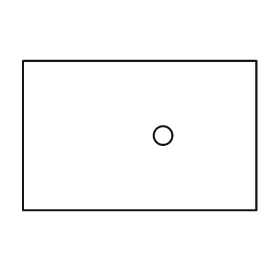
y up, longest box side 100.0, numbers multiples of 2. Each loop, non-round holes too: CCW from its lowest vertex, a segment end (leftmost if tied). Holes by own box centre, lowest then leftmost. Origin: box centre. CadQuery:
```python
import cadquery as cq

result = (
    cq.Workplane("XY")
    .moveTo(-50.0, -32.0)
    .lineTo(50.0, -32.0)
    .lineTo(50.0, 32.0)
    .lineTo(-50.0, 32.0)
    .close()
    .moveTo(10.0, 0.0)
    .circle(4.0)
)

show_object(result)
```